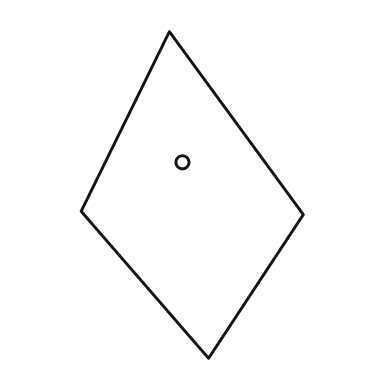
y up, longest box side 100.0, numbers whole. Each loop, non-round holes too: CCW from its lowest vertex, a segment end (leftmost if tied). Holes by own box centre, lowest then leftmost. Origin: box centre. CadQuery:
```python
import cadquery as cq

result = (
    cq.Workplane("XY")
    .moveTo(5.0, -50.0)
    .lineTo(34.0, -6.0)
    .lineTo(-7.0, 50.0)
    .lineTo(-34.0, -5.0)
    .close()
    .moveTo(-3.0, 10.0)
    .circle(2.0)
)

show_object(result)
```